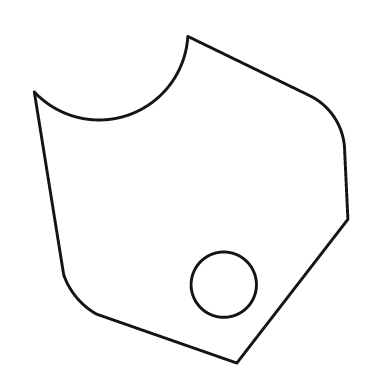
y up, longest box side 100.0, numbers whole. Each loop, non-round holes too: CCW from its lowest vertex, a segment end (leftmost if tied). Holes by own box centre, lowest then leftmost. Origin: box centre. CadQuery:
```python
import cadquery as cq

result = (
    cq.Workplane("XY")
    .moveTo(14.0, -50.0)
    .lineTo(48.0, -6.0)
    .lineTo(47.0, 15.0)
    .threePointArc((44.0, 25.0), (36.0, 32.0))
    .lineTo(-1.0, 50.0)
    .threePointArc((-19.0, 26.0), (-48.0, 33.0))
    .lineTo(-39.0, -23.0)
    .threePointArc((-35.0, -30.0), (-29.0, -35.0))
    .close()
    .moveTo(10.0, -26.0)
    .circle(10.0)
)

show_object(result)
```